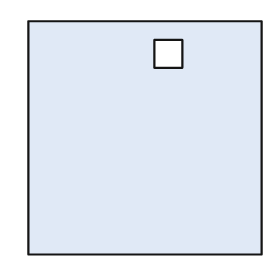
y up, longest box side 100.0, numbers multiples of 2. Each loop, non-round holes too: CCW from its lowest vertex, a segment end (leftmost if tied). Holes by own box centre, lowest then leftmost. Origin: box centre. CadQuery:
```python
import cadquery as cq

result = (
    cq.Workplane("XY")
    .moveTo(-50.0, -50.0)
    .lineTo(50.0, -50.0)
    .lineTo(50.0, 50.0)
    .lineTo(-50.0, 50.0)
    .close()
    .moveTo(4.0, 30.0)
    .lineTo(16.0, 30.0)
    .lineTo(16.0, 42.0)
    .lineTo(4.0, 42.0)
    .close()
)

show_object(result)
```